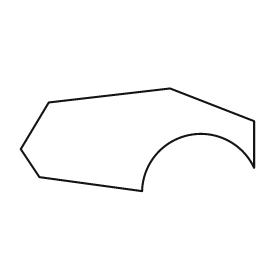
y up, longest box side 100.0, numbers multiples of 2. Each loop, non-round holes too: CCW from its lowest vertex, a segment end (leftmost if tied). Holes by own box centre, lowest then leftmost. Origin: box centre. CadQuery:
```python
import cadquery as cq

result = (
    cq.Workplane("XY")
    .moveTo(2.0, -22.0)
    .threePointArc((22.0, 2.0), (50.0, -12.0))
    .lineTo(50.0, 8.0)
    .lineTo(14.0, 22.0)
    .lineTo(-38.0, 16.0)
    .lineTo(-50.0, -4.0)
    .lineTo(-42.0, -16.0)
    .close()
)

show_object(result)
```